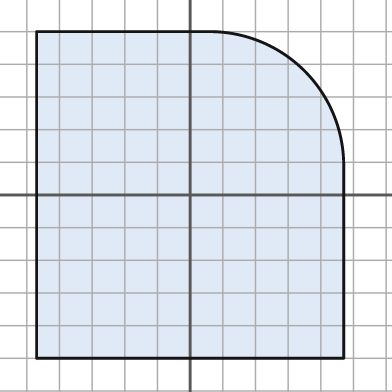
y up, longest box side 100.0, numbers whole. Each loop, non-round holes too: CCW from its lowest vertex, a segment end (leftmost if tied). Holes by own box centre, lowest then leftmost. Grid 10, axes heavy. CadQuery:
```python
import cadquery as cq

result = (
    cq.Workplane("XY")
    .moveTo(-47.0, -50.0)
    .lineTo(47.0, -50.0)
    .lineTo(47.0, 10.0)
    .threePointArc((35.0, 38.0), (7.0, 50.0))
    .lineTo(-47.0, 50.0)
    .close()
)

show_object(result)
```